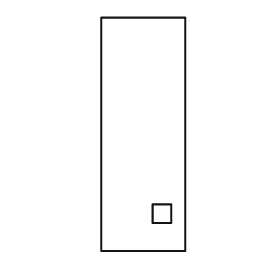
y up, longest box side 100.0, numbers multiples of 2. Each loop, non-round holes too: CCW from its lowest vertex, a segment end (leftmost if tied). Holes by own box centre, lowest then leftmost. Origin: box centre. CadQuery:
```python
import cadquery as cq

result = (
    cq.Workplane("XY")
    .moveTo(-18.0, -50.0)
    .lineTo(18.0, -50.0)
    .lineTo(18.0, 50.0)
    .lineTo(-18.0, 50.0)
    .close()
    .moveTo(4.0, -38.0)
    .lineTo(12.0, -38.0)
    .lineTo(12.0, -30.0)
    .lineTo(4.0, -30.0)
    .close()
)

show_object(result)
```